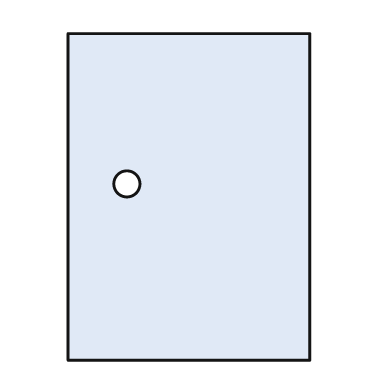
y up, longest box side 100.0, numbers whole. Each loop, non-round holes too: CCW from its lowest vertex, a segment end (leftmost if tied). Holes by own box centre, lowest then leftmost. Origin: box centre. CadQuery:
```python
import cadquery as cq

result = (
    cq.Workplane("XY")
    .moveTo(-37.0, -50.0)
    .lineTo(37.0, -50.0)
    .lineTo(37.0, 50.0)
    .lineTo(-37.0, 50.0)
    .close()
    .moveTo(-19.0, 4.0)
    .circle(4.0)
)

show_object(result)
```